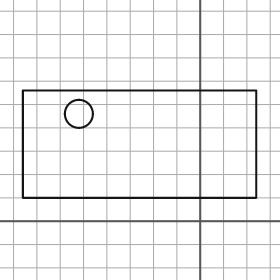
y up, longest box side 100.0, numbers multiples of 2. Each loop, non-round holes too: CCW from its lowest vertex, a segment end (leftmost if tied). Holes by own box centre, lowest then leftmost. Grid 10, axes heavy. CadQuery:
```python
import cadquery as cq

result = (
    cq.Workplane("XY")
    .moveTo(-76.0, 10.0)
    .lineTo(24.0, 10.0)
    .lineTo(24.0, 56.0)
    .lineTo(-76.0, 56.0)
    .close()
    .moveTo(-52.0, 46.0)
    .circle(6.0)
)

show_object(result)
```